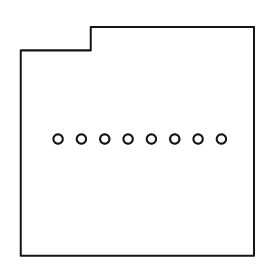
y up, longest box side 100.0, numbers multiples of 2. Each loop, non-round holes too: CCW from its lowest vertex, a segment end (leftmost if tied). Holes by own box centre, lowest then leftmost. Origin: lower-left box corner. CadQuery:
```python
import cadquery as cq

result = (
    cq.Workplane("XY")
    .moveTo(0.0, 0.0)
    .lineTo(100.0, 0.0)
    .lineTo(100.0, 98.0)
    .lineTo(30.0, 98.0)
    .lineTo(30.0, 88.0)
    .lineTo(0.0, 88.0)
    .close()
    .moveTo(16.0, 50.0)
    .circle(2.0)
    .moveTo(26.0, 50.0)
    .circle(2.0)
    .moveTo(36.0, 50.0)
    .circle(2.0)
    .moveTo(46.0, 50.0)
    .circle(2.0)
    .moveTo(56.0, 50.0)
    .circle(2.0)
    .moveTo(66.0, 50.0)
    .circle(2.0)
    .moveTo(76.0, 50.0)
    .circle(2.0)
    .moveTo(86.0, 50.0)
    .circle(2.0)
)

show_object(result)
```